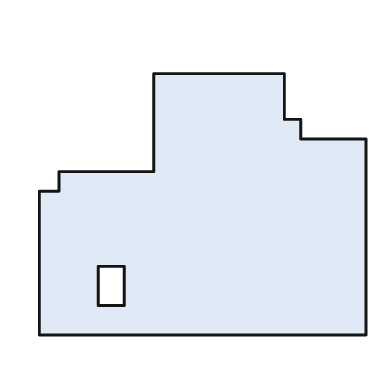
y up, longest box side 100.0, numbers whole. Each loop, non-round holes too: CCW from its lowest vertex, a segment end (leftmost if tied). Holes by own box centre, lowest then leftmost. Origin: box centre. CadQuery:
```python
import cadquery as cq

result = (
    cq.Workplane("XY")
    .moveTo(-50.0, -40.0)
    .lineTo(50.0, -40.0)
    .lineTo(50.0, 20.0)
    .lineTo(30.0, 20.0)
    .lineTo(30.0, 26.0)
    .lineTo(25.0, 26.0)
    .lineTo(25.0, 40.0)
    .lineTo(-15.0, 40.0)
    .lineTo(-15.0, 10.0)
    .lineTo(-44.0, 10.0)
    .lineTo(-44.0, 4.0)
    .lineTo(-50.0, 4.0)
    .close()
    .moveTo(-32.0, -31.0)
    .lineTo(-24.0, -31.0)
    .lineTo(-24.0, -19.0)
    .lineTo(-32.0, -19.0)
    .close()
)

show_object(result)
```